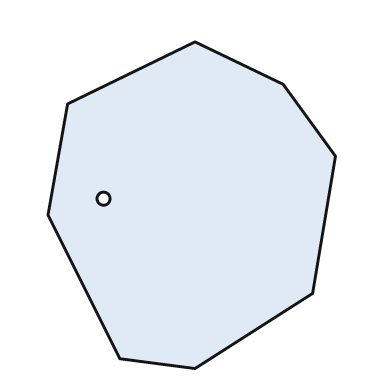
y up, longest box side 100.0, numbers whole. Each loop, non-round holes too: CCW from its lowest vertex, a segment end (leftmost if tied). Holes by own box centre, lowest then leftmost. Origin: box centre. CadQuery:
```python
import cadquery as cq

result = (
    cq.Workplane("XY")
    .moveTo(1.0, -50.0)
    .lineTo(37.0, -27.0)
    .lineTo(44.0, 15.0)
    .lineTo(28.0, 37.0)
    .lineTo(1.0, 50.0)
    .lineTo(-38.0, 31.0)
    .lineTo(-44.0, -3.0)
    .lineTo(-22.0, -47.0)
    .close()
    .moveTo(-27.0, 2.0)
    .circle(2.0)
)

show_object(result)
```